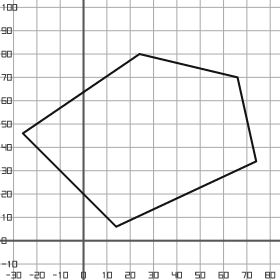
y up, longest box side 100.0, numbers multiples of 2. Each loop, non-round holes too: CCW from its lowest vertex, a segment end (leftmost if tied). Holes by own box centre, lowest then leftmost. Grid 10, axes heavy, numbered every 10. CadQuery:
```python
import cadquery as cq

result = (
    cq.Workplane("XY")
    .moveTo(14.0, 6.0)
    .lineTo(74.0, 34.0)
    .lineTo(66.0, 70.0)
    .lineTo(24.0, 80.0)
    .lineTo(-26.0, 46.0)
    .close()
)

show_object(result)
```